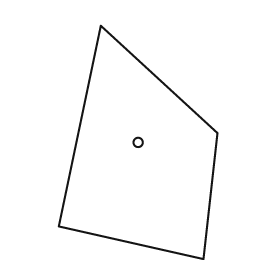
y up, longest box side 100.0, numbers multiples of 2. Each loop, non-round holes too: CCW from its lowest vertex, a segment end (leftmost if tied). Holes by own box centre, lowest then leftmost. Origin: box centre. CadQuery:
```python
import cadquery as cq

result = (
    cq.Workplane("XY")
    .moveTo(28.0, -50.0)
    .lineTo(34.0, 4.0)
    .lineTo(-16.0, 50.0)
    .lineTo(-34.0, -36.0)
    .close()
    .moveTo(0.0, 0.0)
    .circle(2.0)
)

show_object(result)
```